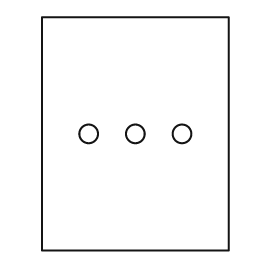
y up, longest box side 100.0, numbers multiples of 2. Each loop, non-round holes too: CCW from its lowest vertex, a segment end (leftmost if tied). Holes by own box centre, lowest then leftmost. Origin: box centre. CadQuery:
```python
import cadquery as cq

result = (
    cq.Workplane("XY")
    .moveTo(-40.0, -50.0)
    .lineTo(40.0, -50.0)
    .lineTo(40.0, 50.0)
    .lineTo(-40.0, 50.0)
    .close()
    .moveTo(-20.0, 0.0)
    .circle(4.0)
    .moveTo(0.0, 0.0)
    .circle(4.0)
    .moveTo(20.0, 0.0)
    .circle(4.0)
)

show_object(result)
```